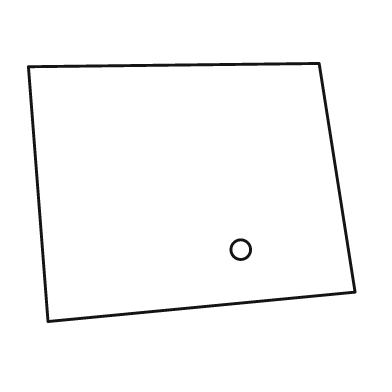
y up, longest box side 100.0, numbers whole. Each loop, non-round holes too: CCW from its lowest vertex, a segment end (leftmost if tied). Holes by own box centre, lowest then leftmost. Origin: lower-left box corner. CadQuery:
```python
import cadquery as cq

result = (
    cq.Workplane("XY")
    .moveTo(6.0, 0.0)
    .lineTo(100.0, 9.0)
    .lineTo(89.0, 79.0)
    .lineTo(0.0, 78.0)
    .close()
    .moveTo(65.0, 22.0)
    .circle(3.0)
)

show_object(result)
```